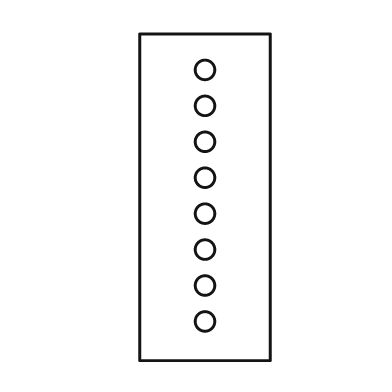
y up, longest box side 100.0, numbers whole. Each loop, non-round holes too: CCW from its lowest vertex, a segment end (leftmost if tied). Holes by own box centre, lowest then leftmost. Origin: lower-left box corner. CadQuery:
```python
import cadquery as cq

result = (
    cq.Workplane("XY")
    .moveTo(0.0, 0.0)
    .lineTo(40.0, 0.0)
    .lineTo(40.0, 100.0)
    .lineTo(0.0, 100.0)
    .close()
    .moveTo(20.0, 12.0)
    .circle(3.0)
    .moveTo(20.0, 23.0)
    .circle(3.0)
    .moveTo(20.0, 34.0)
    .circle(3.0)
    .moveTo(20.0, 45.0)
    .circle(3.0)
    .moveTo(20.0, 56.0)
    .circle(3.0)
    .moveTo(20.0, 67.0)
    .circle(3.0)
    .moveTo(20.0, 78.0)
    .circle(3.0)
    .moveTo(20.0, 89.0)
    .circle(3.0)
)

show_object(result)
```